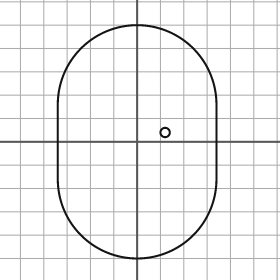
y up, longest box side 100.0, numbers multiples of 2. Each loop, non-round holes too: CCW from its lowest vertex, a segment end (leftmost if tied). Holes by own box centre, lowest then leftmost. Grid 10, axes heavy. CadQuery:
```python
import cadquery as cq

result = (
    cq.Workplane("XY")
    .moveTo(-34.0, -16.0)
    .threePointArc((0.0, -50.0), (34.0, -16.0))
    .lineTo(34.0, 16.0)
    .threePointArc((0.0, 50.0), (-34.0, 16.0))
    .close()
    .moveTo(12.0, 4.0)
    .circle(2.0)
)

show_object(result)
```